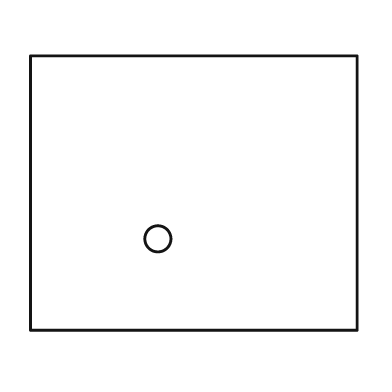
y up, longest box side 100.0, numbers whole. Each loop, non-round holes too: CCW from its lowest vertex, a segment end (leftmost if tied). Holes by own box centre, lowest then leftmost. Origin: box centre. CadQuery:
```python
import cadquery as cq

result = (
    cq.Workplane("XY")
    .moveTo(-50.0, -42.0)
    .lineTo(50.0, -42.0)
    .lineTo(50.0, 42.0)
    .lineTo(-50.0, 42.0)
    .close()
    .moveTo(-11.0, -14.0)
    .circle(4.0)
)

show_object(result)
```